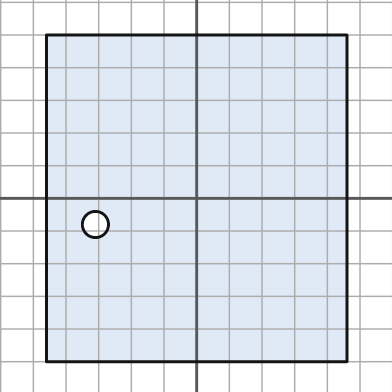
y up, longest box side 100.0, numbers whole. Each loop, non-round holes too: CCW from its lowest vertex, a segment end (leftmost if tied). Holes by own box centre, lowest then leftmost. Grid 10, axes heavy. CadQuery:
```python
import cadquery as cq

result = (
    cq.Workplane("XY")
    .moveTo(-46.0, -50.0)
    .lineTo(46.0, -50.0)
    .lineTo(46.0, 50.0)
    .lineTo(-46.0, 50.0)
    .close()
    .moveTo(-31.0, -8.0)
    .circle(4.0)
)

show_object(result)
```